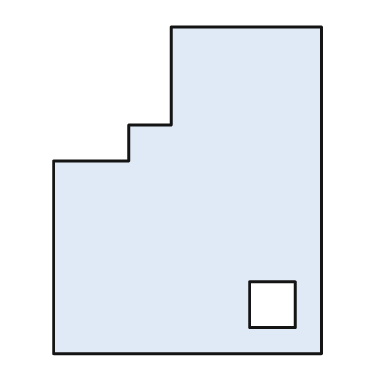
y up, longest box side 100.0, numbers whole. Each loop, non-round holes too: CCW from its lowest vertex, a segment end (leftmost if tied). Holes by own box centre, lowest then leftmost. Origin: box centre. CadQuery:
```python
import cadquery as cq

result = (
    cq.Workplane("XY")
    .moveTo(-41.0, -50.0)
    .lineTo(41.0, -50.0)
    .lineTo(41.0, 50.0)
    .lineTo(-5.0, 50.0)
    .lineTo(-5.0, 20.0)
    .lineTo(-18.0, 20.0)
    .lineTo(-18.0, 9.0)
    .lineTo(-41.0, 9.0)
    .close()
    .moveTo(19.0, -42.0)
    .lineTo(33.0, -42.0)
    .lineTo(33.0, -28.0)
    .lineTo(19.0, -28.0)
    .close()
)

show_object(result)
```